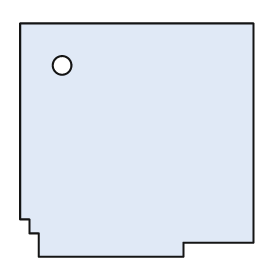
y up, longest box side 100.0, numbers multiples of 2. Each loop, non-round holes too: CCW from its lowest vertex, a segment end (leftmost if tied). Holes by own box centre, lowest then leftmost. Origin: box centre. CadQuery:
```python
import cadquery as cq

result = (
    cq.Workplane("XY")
    .moveTo(-42.0, -50.0)
    .lineTo(20.0, -50.0)
    .lineTo(20.0, -44.0)
    .lineTo(50.0, -44.0)
    .lineTo(50.0, 50.0)
    .lineTo(-50.0, 50.0)
    .lineTo(-50.0, -34.0)
    .lineTo(-46.0, -34.0)
    .lineTo(-46.0, -40.0)
    .lineTo(-42.0, -40.0)
    .close()
    .moveTo(-32.0, 32.0)
    .circle(4.0)
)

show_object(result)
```